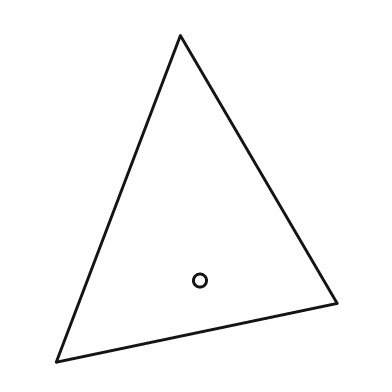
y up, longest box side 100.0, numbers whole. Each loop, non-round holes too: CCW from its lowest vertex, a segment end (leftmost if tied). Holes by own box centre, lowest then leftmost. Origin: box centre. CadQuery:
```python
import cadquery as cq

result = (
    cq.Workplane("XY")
    .moveTo(-43.0, -50.0)
    .lineTo(43.0, -32.0)
    .lineTo(-5.0, 50.0)
    .close()
    .moveTo(1.0, -25.0)
    .circle(2.0)
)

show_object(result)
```